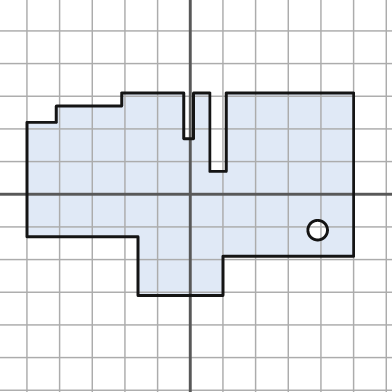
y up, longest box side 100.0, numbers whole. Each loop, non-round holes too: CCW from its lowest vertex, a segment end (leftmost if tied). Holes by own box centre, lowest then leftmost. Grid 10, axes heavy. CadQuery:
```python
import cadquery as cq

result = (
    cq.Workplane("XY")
    .moveTo(-16.0, -31.0)
    .lineTo(10.0, -31.0)
    .lineTo(10.0, -19.0)
    .lineTo(50.0, -19.0)
    .lineTo(50.0, 31.0)
    .lineTo(11.0, 31.0)
    .lineTo(11.0, 7.0)
    .lineTo(6.0, 7.0)
    .lineTo(6.0, 31.0)
    .lineTo(1.0, 31.0)
    .lineTo(1.0, 17.0)
    .lineTo(-2.0, 17.0)
    .lineTo(-2.0, 31.0)
    .lineTo(-21.0, 31.0)
    .lineTo(-21.0, 27.0)
    .lineTo(-41.0, 27.0)
    .lineTo(-41.0, 22.0)
    .lineTo(-50.0, 22.0)
    .lineTo(-50.0, -13.0)
    .lineTo(-16.0, -13.0)
    .close()
    .moveTo(39.0, -11.0)
    .circle(3.0)
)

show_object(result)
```